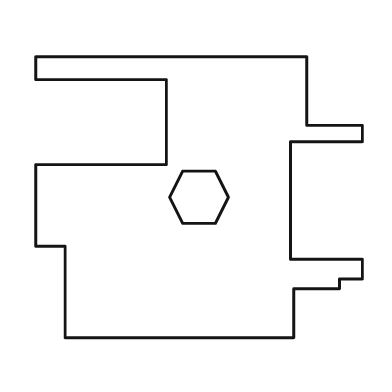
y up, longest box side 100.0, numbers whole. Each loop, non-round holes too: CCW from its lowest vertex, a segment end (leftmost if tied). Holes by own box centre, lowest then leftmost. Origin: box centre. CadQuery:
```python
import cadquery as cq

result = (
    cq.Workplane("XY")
    .moveTo(-41.0, -43.0)
    .lineTo(29.0, -43.0)
    .lineTo(29.0, -28.0)
    .lineTo(43.0, -28.0)
    .lineTo(43.0, -25.0)
    .lineTo(50.0, -25.0)
    .lineTo(50.0, -19.0)
    .lineTo(28.0, -19.0)
    .lineTo(28.0, 17.0)
    .lineTo(50.0, 17.0)
    .lineTo(50.0, 22.0)
    .lineTo(33.0, 22.0)
    .lineTo(33.0, 43.0)
    .lineTo(-50.0, 43.0)
    .lineTo(-50.0, 36.0)
    .lineTo(-10.0, 36.0)
    .lineTo(-10.0, 10.0)
    .lineTo(-50.0, 10.0)
    .lineTo(-50.0, -15.0)
    .lineTo(-41.0, -15.0)
    .close()
    .moveTo(-5.0, -8.0)
    .lineTo(5.0, -8.0)
    .lineTo(9.0, 0.0)
    .lineTo(5.0, 8.0)
    .lineTo(-5.0, 8.0)
    .lineTo(-9.0, 0.0)
    .close()
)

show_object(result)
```